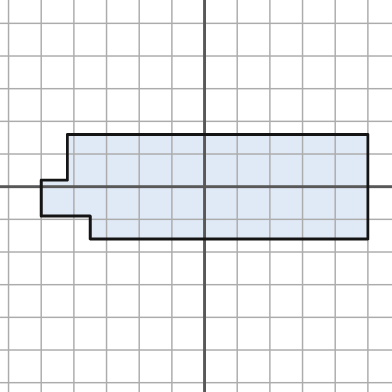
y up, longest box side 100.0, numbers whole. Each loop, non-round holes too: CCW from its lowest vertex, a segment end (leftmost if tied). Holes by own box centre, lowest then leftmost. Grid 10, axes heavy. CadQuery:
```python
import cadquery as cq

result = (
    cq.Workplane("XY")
    .moveTo(-35.0, -16.0)
    .lineTo(50.0, -16.0)
    .lineTo(50.0, 16.0)
    .lineTo(-42.0, 16.0)
    .lineTo(-42.0, 2.0)
    .lineTo(-50.0, 2.0)
    .lineTo(-50.0, -9.0)
    .lineTo(-35.0, -9.0)
    .close()
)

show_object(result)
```